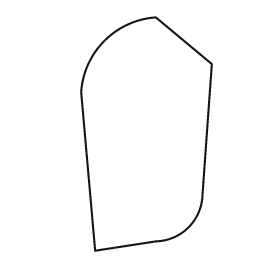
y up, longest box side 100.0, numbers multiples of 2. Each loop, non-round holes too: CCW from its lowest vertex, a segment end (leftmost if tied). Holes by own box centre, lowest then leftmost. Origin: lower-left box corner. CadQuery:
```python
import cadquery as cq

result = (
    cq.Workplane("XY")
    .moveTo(6.0, 0.0)
    .lineTo(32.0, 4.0)
    .threePointArc((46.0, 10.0), (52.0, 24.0))
    .lineTo(56.0, 80.0)
    .lineTo(32.0, 100.0)
    .threePointArc((10.0, 90.0), (0.0, 68.0))
    .close()
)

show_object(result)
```